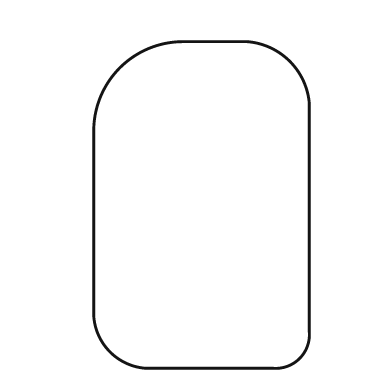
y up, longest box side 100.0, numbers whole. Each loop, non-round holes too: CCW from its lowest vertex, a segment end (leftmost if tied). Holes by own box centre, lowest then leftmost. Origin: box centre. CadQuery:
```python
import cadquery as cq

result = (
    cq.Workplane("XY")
    .moveTo(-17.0, -50.0)
    .lineTo(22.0, -50.0)
    .threePointArc((30.0, -47.0), (33.0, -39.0))
    .lineTo(33.0, 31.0)
    .threePointArc((27.0, 44.0), (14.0, 50.0))
    .lineTo(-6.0, 50.0)
    .threePointArc((-25.0, 42.0), (-33.0, 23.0))
    .lineTo(-33.0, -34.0)
    .threePointArc((-28.0, -45.0), (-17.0, -50.0))
    .close()
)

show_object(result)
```